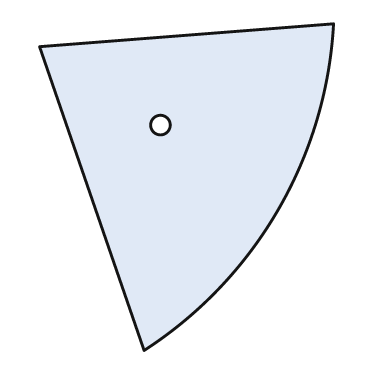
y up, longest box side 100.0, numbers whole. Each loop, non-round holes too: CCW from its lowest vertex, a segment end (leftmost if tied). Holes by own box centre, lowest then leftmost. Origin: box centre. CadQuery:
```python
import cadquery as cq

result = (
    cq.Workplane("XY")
    .moveTo(-13.0, -50.0)
    .threePointArc((28.0, -7.0), (45.0, 50.0))
    .lineTo(-45.0, 43.0)
    .close()
    .moveTo(-8.0, 19.0)
    .circle(3.0)
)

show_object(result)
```